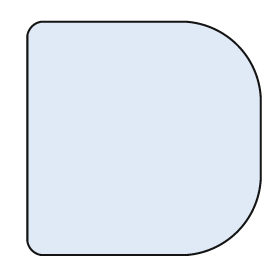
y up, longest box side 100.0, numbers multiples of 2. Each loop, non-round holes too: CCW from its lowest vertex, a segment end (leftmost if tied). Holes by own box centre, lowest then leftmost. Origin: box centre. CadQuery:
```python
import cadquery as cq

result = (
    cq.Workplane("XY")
    .moveTo(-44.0, -50.0)
    .lineTo(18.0, -50.0)
    .threePointArc((40.0, -40.0), (50.0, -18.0))
    .lineTo(50.0, 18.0)
    .threePointArc((40.0, 40.0), (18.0, 50.0))
    .lineTo(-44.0, 50.0)
    .threePointArc((-48.0, 48.0), (-50.0, 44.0))
    .lineTo(-50.0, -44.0)
    .threePointArc((-48.0, -48.0), (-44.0, -50.0))
    .close()
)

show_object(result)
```